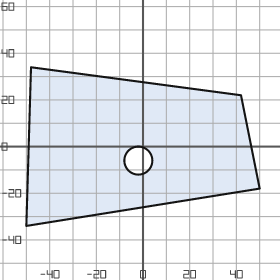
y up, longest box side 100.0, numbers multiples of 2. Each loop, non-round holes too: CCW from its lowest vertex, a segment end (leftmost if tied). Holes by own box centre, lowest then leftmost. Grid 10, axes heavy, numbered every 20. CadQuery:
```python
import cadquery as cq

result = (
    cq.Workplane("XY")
    .moveTo(-50.0, -34.0)
    .lineTo(50.0, -18.0)
    .lineTo(42.0, 22.0)
    .lineTo(-48.0, 34.0)
    .close()
    .moveTo(-2.0, -6.0)
    .circle(6.0)
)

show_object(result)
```